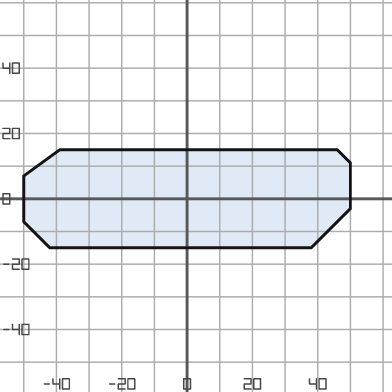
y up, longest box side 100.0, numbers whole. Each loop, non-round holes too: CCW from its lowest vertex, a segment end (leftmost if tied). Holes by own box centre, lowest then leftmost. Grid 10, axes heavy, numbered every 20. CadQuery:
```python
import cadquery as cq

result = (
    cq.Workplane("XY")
    .moveTo(-42.0, -15.0)
    .lineTo(38.0, -15.0)
    .lineTo(50.0, -3.0)
    .lineTo(50.0, 11.0)
    .lineTo(46.0, 15.0)
    .lineTo(-39.0, 15.0)
    .lineTo(-50.0, 7.0)
    .lineTo(-50.0, -7.0)
    .close()
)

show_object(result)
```